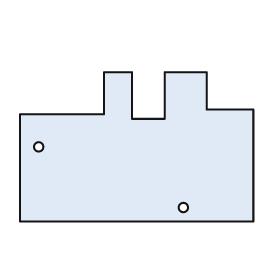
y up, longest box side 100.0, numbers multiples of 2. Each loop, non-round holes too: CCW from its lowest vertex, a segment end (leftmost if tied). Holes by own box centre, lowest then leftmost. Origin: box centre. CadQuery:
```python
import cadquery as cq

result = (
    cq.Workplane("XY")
    .moveTo(-50.0, -32.0)
    .lineTo(50.0, -32.0)
    .lineTo(50.0, 16.0)
    .lineTo(30.0, 16.0)
    .lineTo(30.0, 32.0)
    .lineTo(12.0, 32.0)
    .lineTo(12.0, 12.0)
    .lineTo(-2.0, 12.0)
    .lineTo(-2.0, 32.0)
    .lineTo(-14.0, 32.0)
    .lineTo(-14.0, 14.0)
    .lineTo(-50.0, 14.0)
    .close()
    .moveTo(20.0, -26.0)
    .circle(2.0)
    .moveTo(-42.0, 0.0)
    .circle(2.0)
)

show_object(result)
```